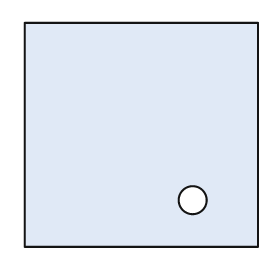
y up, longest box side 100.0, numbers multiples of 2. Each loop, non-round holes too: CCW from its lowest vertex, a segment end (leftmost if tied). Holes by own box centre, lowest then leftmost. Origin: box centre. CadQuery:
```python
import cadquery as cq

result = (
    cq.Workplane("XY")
    .moveTo(-50.0, -48.0)
    .lineTo(50.0, -48.0)
    .lineTo(50.0, 48.0)
    .lineTo(-50.0, 48.0)
    .close()
    .moveTo(22.0, -28.0)
    .circle(6.0)
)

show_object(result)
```